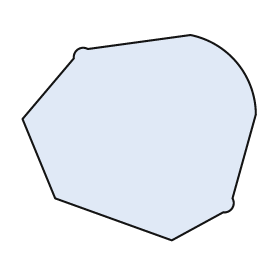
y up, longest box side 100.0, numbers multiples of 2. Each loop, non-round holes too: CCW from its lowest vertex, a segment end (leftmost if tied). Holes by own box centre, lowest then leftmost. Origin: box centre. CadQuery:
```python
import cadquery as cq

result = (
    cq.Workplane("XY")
    .moveTo(14.0, -44.0)
    .lineTo(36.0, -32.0)
    .threePointArc((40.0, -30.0), (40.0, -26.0))
    .lineTo(50.0, 10.0)
    .threePointArc((42.0, 32.0), (22.0, 44.0))
    .lineTo(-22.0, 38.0)
    .threePointArc((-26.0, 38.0), (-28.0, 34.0))
    .lineTo(-50.0, 8.0)
    .lineTo(-36.0, -26.0)
    .close()
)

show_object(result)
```